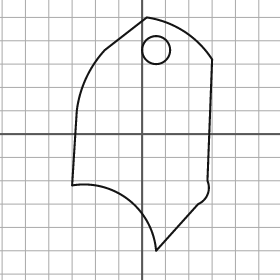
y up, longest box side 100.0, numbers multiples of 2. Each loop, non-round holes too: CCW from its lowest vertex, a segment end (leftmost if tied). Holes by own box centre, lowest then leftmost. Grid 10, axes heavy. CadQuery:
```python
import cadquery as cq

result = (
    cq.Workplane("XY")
    .moveTo(6.0, -50.0)
    .lineTo(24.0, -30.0)
    .threePointArc((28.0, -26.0), (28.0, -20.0))
    .lineTo(30.0, 32.0)
    .threePointArc((18.0, 44.0), (2.0, 50.0))
    .lineTo(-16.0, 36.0)
    .threePointArc((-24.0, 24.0), (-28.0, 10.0))
    .lineTo(-30.0, -22.0)
    .threePointArc((-6.0, -28.0), (6.0, -50.0))
    .close()
    .moveTo(6.0, 36.0)
    .circle(6.0)
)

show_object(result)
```